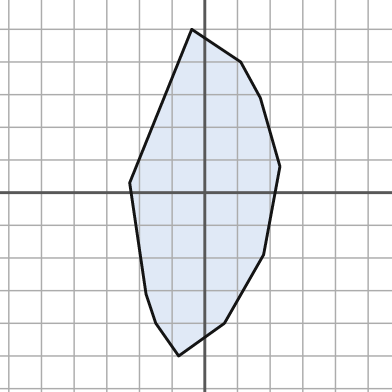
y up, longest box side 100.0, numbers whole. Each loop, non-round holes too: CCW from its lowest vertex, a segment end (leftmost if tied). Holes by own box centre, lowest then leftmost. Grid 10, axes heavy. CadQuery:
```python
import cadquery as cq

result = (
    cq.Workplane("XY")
    .moveTo(-8.0, -50.0)
    .lineTo(6.0, -40.0)
    .lineTo(18.0, -19.0)
    .lineTo(23.0, 8.0)
    .lineTo(17.0, 29.0)
    .lineTo(11.0, 40.0)
    .lineTo(-4.0, 50.0)
    .lineTo(-23.0, 3.0)
    .lineTo(-18.0, -31.0)
    .lineTo(-15.0, -40.0)
    .close()
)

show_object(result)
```